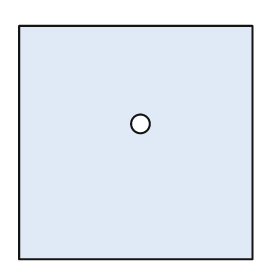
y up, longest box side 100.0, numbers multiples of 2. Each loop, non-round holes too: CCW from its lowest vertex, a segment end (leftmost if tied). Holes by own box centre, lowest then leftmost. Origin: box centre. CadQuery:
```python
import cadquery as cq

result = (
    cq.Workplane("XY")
    .moveTo(-50.0, -50.0)
    .lineTo(50.0, -50.0)
    .lineTo(50.0, 50.0)
    .lineTo(-50.0, 50.0)
    .close()
    .moveTo(2.0, 8.0)
    .circle(4.0)
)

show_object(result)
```